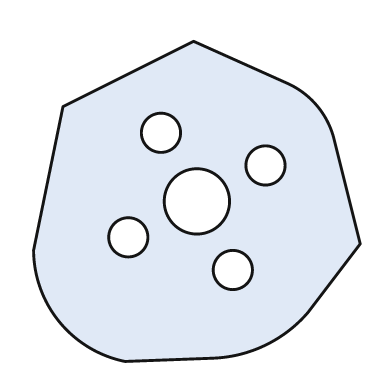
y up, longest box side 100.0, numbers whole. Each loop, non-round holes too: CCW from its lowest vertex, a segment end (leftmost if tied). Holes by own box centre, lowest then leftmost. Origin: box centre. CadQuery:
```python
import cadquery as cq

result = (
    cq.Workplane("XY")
    .moveTo(-22.0, -49.0)
    .lineTo(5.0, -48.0)
    .threePointArc((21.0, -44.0), (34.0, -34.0))
    .lineTo(50.0, -13.0)
    .lineTo(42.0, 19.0)
    .threePointArc((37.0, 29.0), (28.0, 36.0))
    .lineTo(-1.0, 49.0)
    .lineTo(-41.0, 29.0)
    .lineTo(-50.0, -15.0)
    .threePointArc((-42.0, -37.0), (-22.0, -49.0))
    .close()
    .moveTo(11.0, -21.0)
    .circle(6.0)
    .moveTo(-21.0, -11.0)
    .circle(6.0)
    .moveTo(0.0, 0.0)
    .circle(10.0)
    .moveTo(21.0, 11.0)
    .circle(6.0)
    .moveTo(-11.0, 21.0)
    .circle(6.0)
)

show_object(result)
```